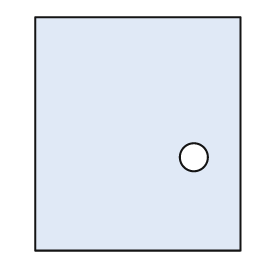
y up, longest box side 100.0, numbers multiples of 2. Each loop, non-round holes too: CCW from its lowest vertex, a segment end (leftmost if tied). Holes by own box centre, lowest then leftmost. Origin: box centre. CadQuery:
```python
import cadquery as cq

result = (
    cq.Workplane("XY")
    .moveTo(-44.0, -50.0)
    .lineTo(44.0, -50.0)
    .lineTo(44.0, 50.0)
    .lineTo(-44.0, 50.0)
    .close()
    .moveTo(24.0, -10.0)
    .circle(6.0)
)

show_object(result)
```